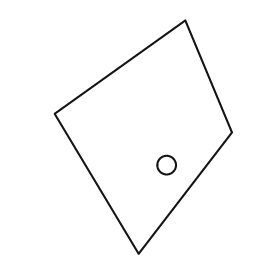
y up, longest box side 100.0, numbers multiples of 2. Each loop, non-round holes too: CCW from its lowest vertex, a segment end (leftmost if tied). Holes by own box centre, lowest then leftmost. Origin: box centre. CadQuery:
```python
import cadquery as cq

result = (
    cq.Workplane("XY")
    .moveTo(-2.0, -50.0)
    .lineTo(38.0, 2.0)
    .lineTo(18.0, 50.0)
    .lineTo(-38.0, 10.0)
    .close()
    .moveTo(10.0, -12.0)
    .circle(4.0)
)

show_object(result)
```